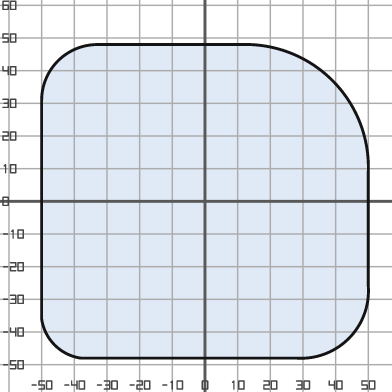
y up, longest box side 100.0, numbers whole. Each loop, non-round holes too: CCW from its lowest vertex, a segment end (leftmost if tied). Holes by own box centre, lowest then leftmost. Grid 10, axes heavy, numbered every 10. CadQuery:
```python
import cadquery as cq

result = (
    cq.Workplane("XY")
    .moveTo(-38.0, -48.0)
    .lineTo(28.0, -48.0)
    .threePointArc((44.0, -42.0), (50.0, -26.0))
    .lineTo(50.0, 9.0)
    .threePointArc((39.0, 37.0), (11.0, 48.0))
    .lineTo(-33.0, 48.0)
    .threePointArc((-45.0, 43.0), (-50.0, 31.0))
    .lineTo(-50.0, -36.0)
    .threePointArc((-46.0, -44.0), (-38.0, -48.0))
    .close()
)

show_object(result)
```